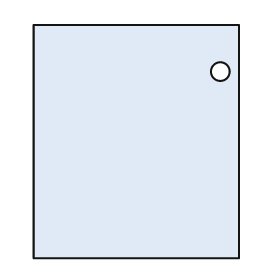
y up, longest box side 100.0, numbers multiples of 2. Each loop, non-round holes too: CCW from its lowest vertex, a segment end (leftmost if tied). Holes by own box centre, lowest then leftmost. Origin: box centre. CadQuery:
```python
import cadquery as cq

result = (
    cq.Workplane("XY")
    .moveTo(-44.0, -50.0)
    .lineTo(44.0, -50.0)
    .lineTo(44.0, 50.0)
    .lineTo(-44.0, 50.0)
    .close()
    .moveTo(36.0, 30.0)
    .circle(4.0)
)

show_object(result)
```